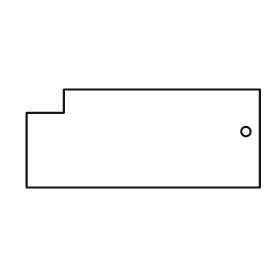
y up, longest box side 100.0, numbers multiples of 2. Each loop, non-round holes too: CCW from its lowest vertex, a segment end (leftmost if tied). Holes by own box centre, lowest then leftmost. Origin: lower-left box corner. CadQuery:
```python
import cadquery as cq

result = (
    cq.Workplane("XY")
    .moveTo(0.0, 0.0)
    .lineTo(100.0, 0.0)
    .lineTo(100.0, 42.0)
    .lineTo(16.0, 42.0)
    .lineTo(16.0, 32.0)
    .lineTo(0.0, 32.0)
    .close()
    .moveTo(94.0, 24.0)
    .circle(2.0)
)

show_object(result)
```